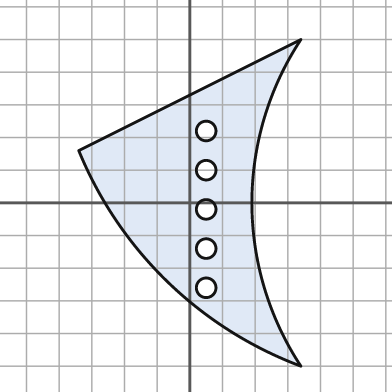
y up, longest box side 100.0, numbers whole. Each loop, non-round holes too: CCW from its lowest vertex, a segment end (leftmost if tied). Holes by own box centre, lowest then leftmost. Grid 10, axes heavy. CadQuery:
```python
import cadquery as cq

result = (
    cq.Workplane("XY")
    .moveTo(34.0, -50.0)
    .threePointArc((19.0, 0.0), (34.0, 50.0))
    .lineTo(-34.0, 16.0)
    .threePointArc((-7.0, -24.0), (34.0, -50.0))
    .close()
    .moveTo(5.0, -26.0)
    .circle(3.0)
    .moveTo(5.0, -14.0)
    .circle(3.0)
    .moveTo(5.0, -2.0)
    .circle(3.0)
    .moveTo(5.0, 10.0)
    .circle(3.0)
    .moveTo(5.0, 22.0)
    .circle(3.0)
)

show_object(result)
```